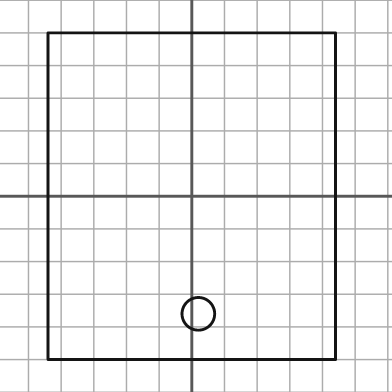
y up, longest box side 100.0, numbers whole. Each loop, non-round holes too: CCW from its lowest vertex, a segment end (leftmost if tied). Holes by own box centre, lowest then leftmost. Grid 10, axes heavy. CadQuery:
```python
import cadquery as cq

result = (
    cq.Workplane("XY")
    .moveTo(-44.0, -50.0)
    .lineTo(44.0, -50.0)
    .lineTo(44.0, 50.0)
    .lineTo(-44.0, 50.0)
    .close()
    .moveTo(2.0, -36.0)
    .circle(5.0)
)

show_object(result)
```